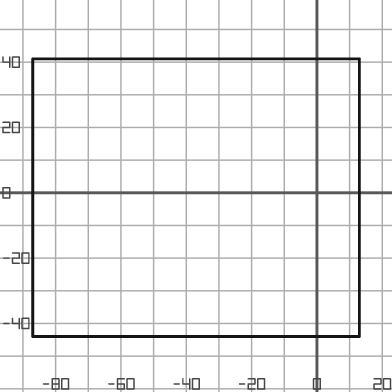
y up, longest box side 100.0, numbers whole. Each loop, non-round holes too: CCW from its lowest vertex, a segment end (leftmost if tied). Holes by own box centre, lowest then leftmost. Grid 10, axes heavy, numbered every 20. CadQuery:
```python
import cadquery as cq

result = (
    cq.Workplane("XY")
    .moveTo(-87.0, -44.0)
    .lineTo(13.0, -44.0)
    .lineTo(13.0, 41.0)
    .lineTo(-87.0, 41.0)
    .close()
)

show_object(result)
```